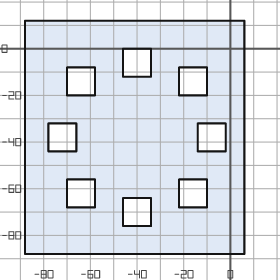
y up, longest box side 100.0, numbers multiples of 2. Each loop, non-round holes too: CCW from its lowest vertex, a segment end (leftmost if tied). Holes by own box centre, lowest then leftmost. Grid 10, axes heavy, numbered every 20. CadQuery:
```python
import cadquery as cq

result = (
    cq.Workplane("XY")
    .moveTo(-88.0, -88.0)
    .lineTo(6.0, -88.0)
    .lineTo(6.0, 12.0)
    .lineTo(-88.0, 12.0)
    .close()
    .moveTo(-46.0, -76.0)
    .lineTo(-34.0, -76.0)
    .lineTo(-34.0, -64.0)
    .lineTo(-46.0, -64.0)
    .close()
    .moveTo(-70.0, -68.0)
    .lineTo(-58.0, -68.0)
    .lineTo(-58.0, -56.0)
    .lineTo(-70.0, -56.0)
    .close()
    .moveTo(-22.0, -68.0)
    .lineTo(-10.0, -68.0)
    .lineTo(-10.0, -56.0)
    .lineTo(-22.0, -56.0)
    .close()
    .moveTo(-78.0, -44.0)
    .lineTo(-66.0, -44.0)
    .lineTo(-66.0, -32.0)
    .lineTo(-78.0, -32.0)
    .close()
    .moveTo(-14.0, -44.0)
    .lineTo(-2.0, -44.0)
    .lineTo(-2.0, -32.0)
    .lineTo(-14.0, -32.0)
    .close()
    .moveTo(-70.0, -20.0)
    .lineTo(-58.0, -20.0)
    .lineTo(-58.0, -8.0)
    .lineTo(-70.0, -8.0)
    .close()
    .moveTo(-22.0, -20.0)
    .lineTo(-10.0, -20.0)
    .lineTo(-10.0, -8.0)
    .lineTo(-22.0, -8.0)
    .close()
    .moveTo(-46.0, -12.0)
    .lineTo(-34.0, -12.0)
    .lineTo(-34.0, 0.0)
    .lineTo(-46.0, 0.0)
    .close()
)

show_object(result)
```